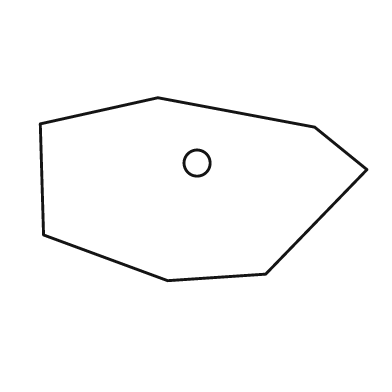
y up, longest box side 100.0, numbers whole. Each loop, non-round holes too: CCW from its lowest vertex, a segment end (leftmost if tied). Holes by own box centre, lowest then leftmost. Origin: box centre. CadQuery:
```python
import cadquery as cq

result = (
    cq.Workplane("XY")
    .moveTo(-11.0, -28.0)
    .lineTo(19.0, -26.0)
    .lineTo(50.0, 6.0)
    .lineTo(34.0, 19.0)
    .lineTo(-14.0, 28.0)
    .lineTo(-50.0, 20.0)
    .lineTo(-49.0, -14.0)
    .close()
    .moveTo(-2.0, 8.0)
    .circle(4.0)
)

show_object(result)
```